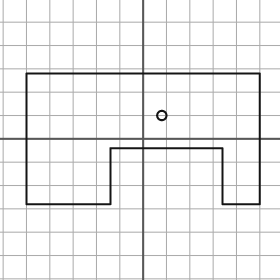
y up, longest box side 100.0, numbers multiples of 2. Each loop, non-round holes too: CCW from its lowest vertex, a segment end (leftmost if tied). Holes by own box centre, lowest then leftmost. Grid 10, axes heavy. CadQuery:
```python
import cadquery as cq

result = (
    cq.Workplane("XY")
    .moveTo(-50.0, -28.0)
    .lineTo(-14.0, -28.0)
    .lineTo(-14.0, -4.0)
    .lineTo(34.0, -4.0)
    .lineTo(34.0, -28.0)
    .lineTo(50.0, -28.0)
    .lineTo(50.0, 28.0)
    .lineTo(-50.0, 28.0)
    .close()
    .moveTo(8.0, 10.0)
    .circle(2.0)
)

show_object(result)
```